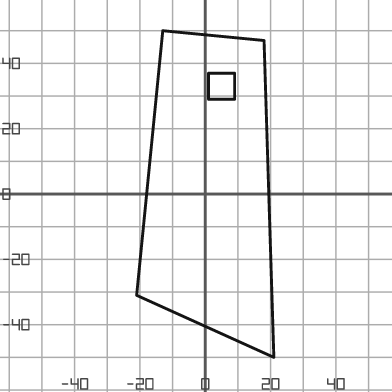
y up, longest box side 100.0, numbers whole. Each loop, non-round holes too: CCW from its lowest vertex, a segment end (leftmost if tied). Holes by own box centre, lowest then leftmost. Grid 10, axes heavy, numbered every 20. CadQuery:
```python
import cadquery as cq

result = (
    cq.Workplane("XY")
    .moveTo(21.0, -50.0)
    .lineTo(18.0, 47.0)
    .lineTo(-13.0, 50.0)
    .lineTo(-21.0, -31.0)
    .close()
    .moveTo(1.0, 29.0)
    .lineTo(9.0, 29.0)
    .lineTo(9.0, 37.0)
    .lineTo(1.0, 37.0)
    .close()
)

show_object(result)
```